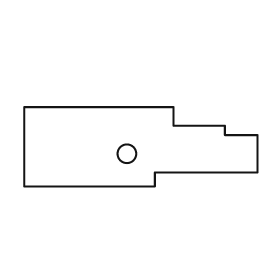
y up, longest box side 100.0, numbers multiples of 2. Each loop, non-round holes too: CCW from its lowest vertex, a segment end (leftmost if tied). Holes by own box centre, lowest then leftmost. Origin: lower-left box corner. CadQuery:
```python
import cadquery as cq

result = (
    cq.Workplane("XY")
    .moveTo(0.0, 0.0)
    .lineTo(56.0, 0.0)
    .lineTo(56.0, 6.0)
    .lineTo(100.0, 6.0)
    .lineTo(100.0, 22.0)
    .lineTo(86.0, 22.0)
    .lineTo(86.0, 26.0)
    .lineTo(64.0, 26.0)
    .lineTo(64.0, 34.0)
    .lineTo(0.0, 34.0)
    .close()
    .moveTo(44.0, 14.0)
    .circle(4.0)
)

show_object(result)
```